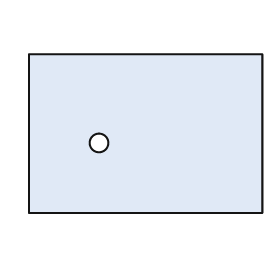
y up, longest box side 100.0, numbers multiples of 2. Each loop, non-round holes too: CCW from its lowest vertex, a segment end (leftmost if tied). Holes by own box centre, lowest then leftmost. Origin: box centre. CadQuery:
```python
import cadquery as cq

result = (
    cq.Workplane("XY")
    .moveTo(-50.0, -34.0)
    .lineTo(50.0, -34.0)
    .lineTo(50.0, 34.0)
    .lineTo(-50.0, 34.0)
    .close()
    .moveTo(-20.0, -4.0)
    .circle(4.0)
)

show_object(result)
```